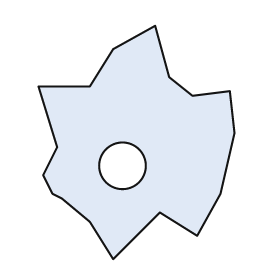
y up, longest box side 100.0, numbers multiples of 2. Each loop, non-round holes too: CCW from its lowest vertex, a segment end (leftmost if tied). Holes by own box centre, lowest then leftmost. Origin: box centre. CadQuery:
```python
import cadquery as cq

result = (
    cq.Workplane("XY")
    .moveTo(-10.0, -50.0)
    .lineTo(10.0, -30.0)
    .lineTo(26.0, -40.0)
    .lineTo(36.0, -22.0)
    .lineTo(42.0, 4.0)
    .lineTo(40.0, 22.0)
    .lineTo(24.0, 20.0)
    .lineTo(14.0, 28.0)
    .lineTo(8.0, 50.0)
    .lineTo(-10.0, 40.0)
    .lineTo(-20.0, 24.0)
    .lineTo(-42.0, 24.0)
    .lineTo(-34.0, -2.0)
    .lineTo(-40.0, -14.0)
    .lineTo(-36.0, -22.0)
    .lineTo(-32.0, -24.0)
    .lineTo(-20.0, -34.0)
    .close()
    .moveTo(-6.0, -10.0)
    .circle(10.0)
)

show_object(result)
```